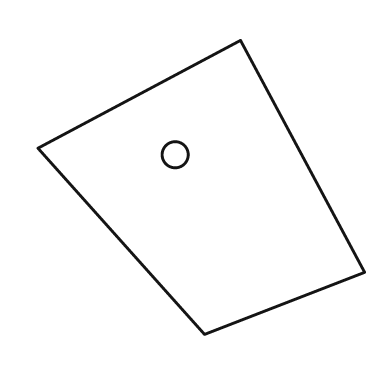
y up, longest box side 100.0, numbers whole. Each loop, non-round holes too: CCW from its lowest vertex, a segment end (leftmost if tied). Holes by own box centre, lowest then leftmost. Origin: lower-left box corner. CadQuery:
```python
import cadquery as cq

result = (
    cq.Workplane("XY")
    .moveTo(51.0, 0.0)
    .lineTo(100.0, 19.0)
    .lineTo(62.0, 90.0)
    .lineTo(0.0, 57.0)
    .close()
    .moveTo(42.0, 55.0)
    .circle(4.0)
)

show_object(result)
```